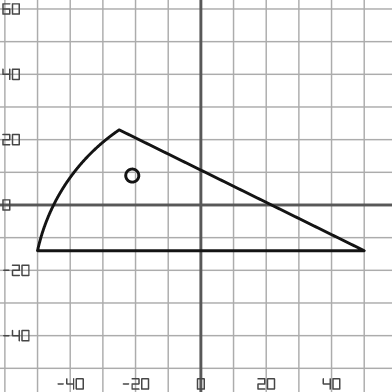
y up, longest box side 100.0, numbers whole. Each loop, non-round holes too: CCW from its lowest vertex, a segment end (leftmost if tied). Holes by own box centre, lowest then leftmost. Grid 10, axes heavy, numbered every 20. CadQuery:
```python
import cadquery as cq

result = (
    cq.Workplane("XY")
    .moveTo(-50.0, -14.0)
    .lineTo(50.0, -14.0)
    .lineTo(-25.0, 23.0)
    .threePointArc((-41.0, 7.0), (-50.0, -14.0))
    .close()
    .moveTo(-21.0, 9.0)
    .circle(2.0)
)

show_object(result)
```